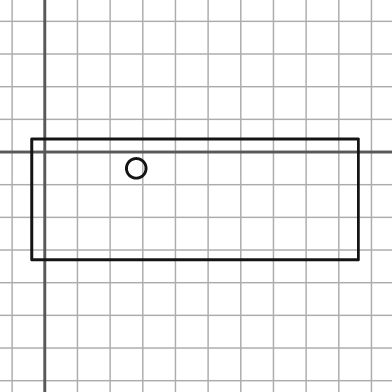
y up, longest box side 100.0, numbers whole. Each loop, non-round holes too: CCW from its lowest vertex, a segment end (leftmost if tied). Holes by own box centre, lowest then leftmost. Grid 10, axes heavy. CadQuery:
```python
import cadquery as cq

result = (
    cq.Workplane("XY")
    .moveTo(-4.0, -33.0)
    .lineTo(96.0, -33.0)
    .lineTo(96.0, 4.0)
    .lineTo(-4.0, 4.0)
    .close()
    .moveTo(28.0, -5.0)
    .circle(3.0)
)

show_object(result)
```